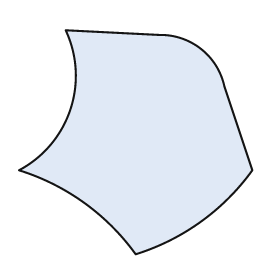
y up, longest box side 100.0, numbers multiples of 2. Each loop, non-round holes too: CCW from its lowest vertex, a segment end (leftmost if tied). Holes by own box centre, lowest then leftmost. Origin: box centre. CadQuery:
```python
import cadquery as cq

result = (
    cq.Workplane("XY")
    .moveTo(0.0, -48.0)
    .threePointArc((28.0, -34.0), (50.0, -12.0))
    .lineTo(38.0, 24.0)
    .threePointArc((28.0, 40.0), (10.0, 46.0))
    .lineTo(-30.0, 48.0)
    .threePointArc((-28.0, 14.0), (-50.0, -12.0))
    .threePointArc((-22.0, -26.0), (0.0, -48.0))
    .close()
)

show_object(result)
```